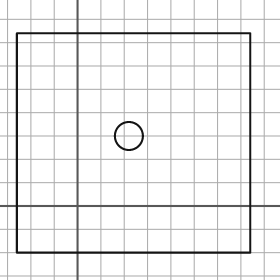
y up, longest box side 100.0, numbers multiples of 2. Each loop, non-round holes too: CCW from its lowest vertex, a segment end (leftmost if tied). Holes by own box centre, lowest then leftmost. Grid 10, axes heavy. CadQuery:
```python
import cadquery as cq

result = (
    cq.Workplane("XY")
    .moveTo(-26.0, -20.0)
    .lineTo(74.0, -20.0)
    .lineTo(74.0, 74.0)
    .lineTo(-26.0, 74.0)
    .close()
    .moveTo(22.0, 30.0)
    .circle(6.0)
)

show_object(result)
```